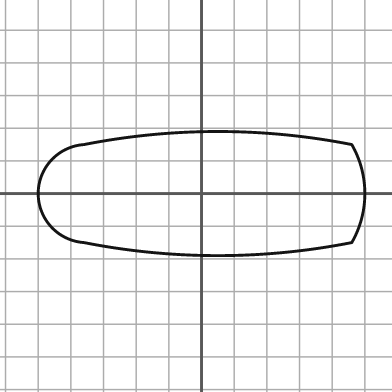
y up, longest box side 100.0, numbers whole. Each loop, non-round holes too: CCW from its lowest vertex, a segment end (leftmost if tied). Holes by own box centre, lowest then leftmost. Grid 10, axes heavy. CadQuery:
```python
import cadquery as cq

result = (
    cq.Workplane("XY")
    .moveTo(-36.0, -15.0)
    .threePointArc((5.0, -19.0), (46.0, -15.0))
    .threePointArc((50.0, 0.0), (46.0, 15.0))
    .threePointArc((5.0, 19.0), (-36.0, 15.0))
    .threePointArc((-50.0, 0.0), (-36.0, -15.0))
    .close()
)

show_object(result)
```